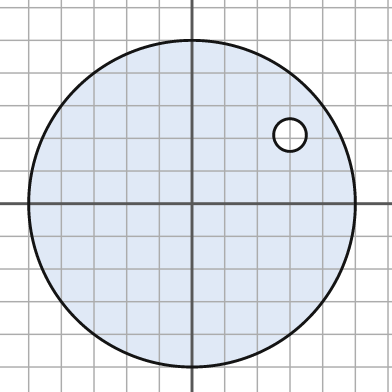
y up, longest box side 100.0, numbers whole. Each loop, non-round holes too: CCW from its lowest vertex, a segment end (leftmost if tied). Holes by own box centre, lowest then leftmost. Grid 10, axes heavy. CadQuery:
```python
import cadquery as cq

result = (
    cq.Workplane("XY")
    .moveTo(0.0, 0.0)
    .circle(50.0)
    .moveTo(30.0, 21.0)
    .circle(5.0)
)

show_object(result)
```